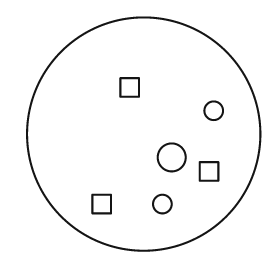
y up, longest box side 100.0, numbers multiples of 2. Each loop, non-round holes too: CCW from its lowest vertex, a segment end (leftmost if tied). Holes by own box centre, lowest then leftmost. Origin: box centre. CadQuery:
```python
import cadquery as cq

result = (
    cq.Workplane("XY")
    .moveTo(0.0, 0.0)
    .circle(50.0)
    .moveTo(-22.0, -34.0)
    .lineTo(-14.0, -34.0)
    .lineTo(-14.0, -26.0)
    .lineTo(-22.0, -26.0)
    .close()
    .moveTo(8.0, -30.0)
    .circle(4.0)
    .moveTo(24.0, -20.0)
    .lineTo(32.0, -20.0)
    .lineTo(32.0, -12.0)
    .lineTo(24.0, -12.0)
    .close()
    .moveTo(12.0, -10.0)
    .circle(6.0)
    .moveTo(30.0, 10.0)
    .circle(4.0)
    .moveTo(-10.0, 16.0)
    .lineTo(-2.0, 16.0)
    .lineTo(-2.0, 24.0)
    .lineTo(-10.0, 24.0)
    .close()
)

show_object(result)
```